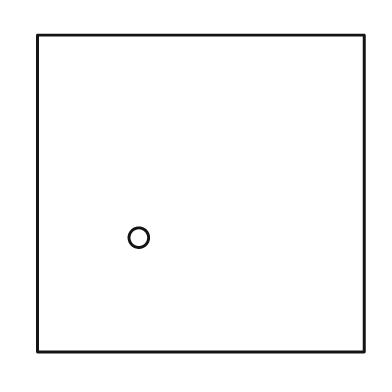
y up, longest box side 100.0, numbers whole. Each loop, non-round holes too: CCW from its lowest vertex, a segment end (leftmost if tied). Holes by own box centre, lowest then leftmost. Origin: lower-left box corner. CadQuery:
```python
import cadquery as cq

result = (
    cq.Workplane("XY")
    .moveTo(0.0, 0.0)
    .lineTo(100.0, 0.0)
    .lineTo(100.0, 97.0)
    .lineTo(0.0, 97.0)
    .close()
    .moveTo(31.0, 35.0)
    .circle(3.0)
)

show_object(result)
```